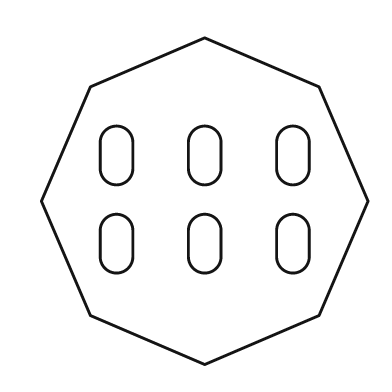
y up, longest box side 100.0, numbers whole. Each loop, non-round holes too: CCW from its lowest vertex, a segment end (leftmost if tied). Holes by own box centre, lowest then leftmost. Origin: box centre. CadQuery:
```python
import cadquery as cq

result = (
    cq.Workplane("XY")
    .moveTo(0.0, -50.0)
    .lineTo(35.0, -35.0)
    .lineTo(50.0, 0.0)
    .lineTo(35.0, 35.0)
    .lineTo(0.0, 50.0)
    .lineTo(-35.0, 35.0)
    .lineTo(-50.0, 0.0)
    .lineTo(-35.0, -35.0)
    .close()
    .moveTo(-32.0, -17.0)
    .threePointArc((-27.0, -22.0), (-22.0, -17.0))
    .lineTo(-22.0, -9.0)
    .threePointArc((-27.0, -4.0), (-32.0, -9.0))
    .close()
    .moveTo(-5.0, -17.0)
    .threePointArc((0.0, -22.0), (5.0, -17.0))
    .lineTo(5.0, -9.0)
    .threePointArc((0.0, -4.0), (-5.0, -9.0))
    .close()
    .moveTo(22.0, -17.0)
    .threePointArc((27.0, -22.0), (32.0, -17.0))
    .lineTo(32.0, -9.0)
    .threePointArc((27.0, -4.0), (22.0, -9.0))
    .close()
    .moveTo(-32.0, 10.0)
    .threePointArc((-27.0, 5.0), (-22.0, 10.0))
    .lineTo(-22.0, 18.0)
    .threePointArc((-27.0, 23.0), (-32.0, 18.0))
    .close()
    .moveTo(-5.0, 10.0)
    .threePointArc((0.0, 5.0), (5.0, 10.0))
    .lineTo(5.0, 18.0)
    .threePointArc((0.0, 23.0), (-5.0, 18.0))
    .close()
    .moveTo(22.0, 10.0)
    .threePointArc((27.0, 5.0), (32.0, 10.0))
    .lineTo(32.0, 18.0)
    .threePointArc((27.0, 23.0), (22.0, 18.0))
    .close()
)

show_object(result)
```